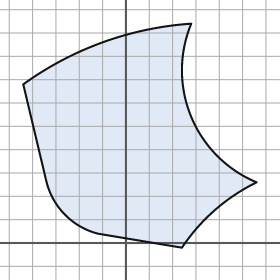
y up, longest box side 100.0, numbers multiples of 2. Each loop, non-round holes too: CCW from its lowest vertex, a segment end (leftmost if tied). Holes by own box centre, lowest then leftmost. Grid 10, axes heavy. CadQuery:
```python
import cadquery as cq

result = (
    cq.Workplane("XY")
    .moveTo(24.0, -2.0)
    .threePointArc((38.0, 14.0), (56.0, 26.0))
    .threePointArc((28.0, 54.0), (28.0, 94.0))
    .threePointArc((-10.0, 86.0), (-44.0, 68.0))
    .lineTo(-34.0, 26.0)
    .threePointArc((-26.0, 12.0), (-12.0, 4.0))
    .close()
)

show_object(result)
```